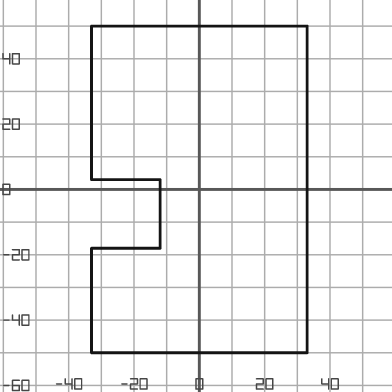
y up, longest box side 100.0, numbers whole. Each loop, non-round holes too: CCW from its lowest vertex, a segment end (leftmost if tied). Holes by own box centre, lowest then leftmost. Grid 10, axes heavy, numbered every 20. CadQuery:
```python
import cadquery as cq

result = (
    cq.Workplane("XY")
    .moveTo(-33.0, -50.0)
    .lineTo(33.0, -50.0)
    .lineTo(33.0, 50.0)
    .lineTo(-33.0, 50.0)
    .lineTo(-33.0, 3.0)
    .lineTo(-12.0, 3.0)
    .lineTo(-12.0, -18.0)
    .lineTo(-33.0, -18.0)
    .close()
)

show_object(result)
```